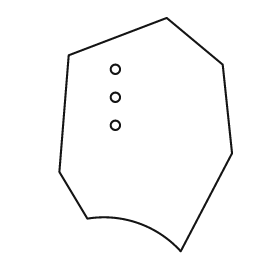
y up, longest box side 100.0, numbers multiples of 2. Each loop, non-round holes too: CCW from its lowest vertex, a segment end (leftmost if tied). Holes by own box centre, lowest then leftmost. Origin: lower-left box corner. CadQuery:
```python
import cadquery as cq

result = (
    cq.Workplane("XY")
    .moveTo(52.0, 0.0)
    .lineTo(74.0, 42.0)
    .lineTo(70.0, 80.0)
    .lineTo(46.0, 100.0)
    .lineTo(4.0, 84.0)
    .lineTo(0.0, 34.0)
    .lineTo(12.0, 14.0)
    .threePointArc((34.0, 12.0), (52.0, 0.0))
    .close()
    .moveTo(24.0, 54.0)
    .circle(2.0)
    .moveTo(24.0, 66.0)
    .circle(2.0)
    .moveTo(24.0, 78.0)
    .circle(2.0)
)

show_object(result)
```